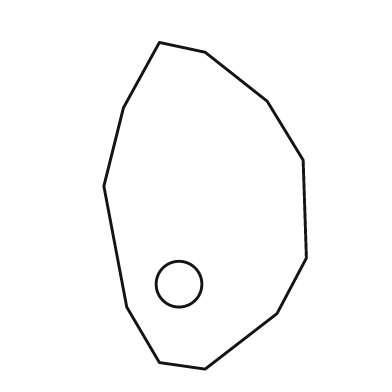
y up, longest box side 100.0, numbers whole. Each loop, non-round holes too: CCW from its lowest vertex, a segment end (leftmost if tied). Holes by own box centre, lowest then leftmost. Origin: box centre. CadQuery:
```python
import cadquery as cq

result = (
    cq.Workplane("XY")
    .moveTo(0.0, -50.0)
    .lineTo(22.0, -33.0)
    .lineTo(31.0, -16.0)
    .lineTo(30.0, 14.0)
    .lineTo(19.0, 32.0)
    .lineTo(0.0, 47.0)
    .lineTo(-14.0, 50.0)
    .lineTo(-25.0, 30.0)
    .lineTo(-31.0, 6.0)
    .lineTo(-24.0, -31.0)
    .lineTo(-14.0, -48.0)
    .close()
    .moveTo(-8.0, -24.0)
    .circle(7.0)
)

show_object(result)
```